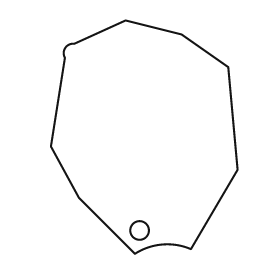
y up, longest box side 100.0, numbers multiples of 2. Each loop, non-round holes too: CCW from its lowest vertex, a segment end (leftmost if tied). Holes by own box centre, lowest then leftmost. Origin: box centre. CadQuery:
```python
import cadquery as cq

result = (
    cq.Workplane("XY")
    .moveTo(-4.0, -50.0)
    .threePointArc((8.0, -46.0), (20.0, -48.0))
    .lineTo(40.0, -14.0)
    .lineTo(36.0, 30.0)
    .lineTo(16.0, 44.0)
    .lineTo(-8.0, 50.0)
    .lineTo(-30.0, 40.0)
    .threePointArc((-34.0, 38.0), (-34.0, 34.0))
    .lineTo(-40.0, -4.0)
    .lineTo(-28.0, -26.0)
    .close()
    .moveTo(-2.0, -40.0)
    .circle(4.0)
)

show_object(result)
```